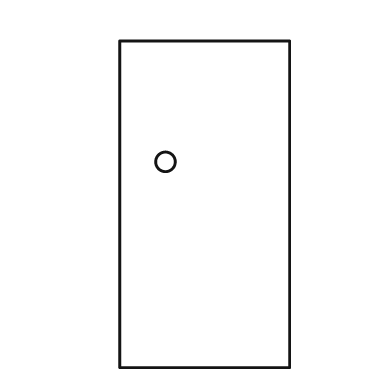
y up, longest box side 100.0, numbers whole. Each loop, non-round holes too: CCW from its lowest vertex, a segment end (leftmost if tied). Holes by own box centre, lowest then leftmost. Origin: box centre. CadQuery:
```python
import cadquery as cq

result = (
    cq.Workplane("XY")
    .moveTo(-26.0, -50.0)
    .lineTo(26.0, -50.0)
    .lineTo(26.0, 50.0)
    .lineTo(-26.0, 50.0)
    .close()
    .moveTo(-12.0, 13.0)
    .circle(3.0)
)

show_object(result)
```